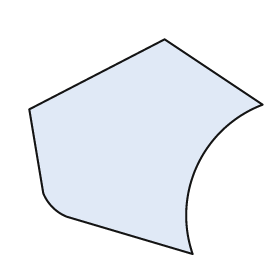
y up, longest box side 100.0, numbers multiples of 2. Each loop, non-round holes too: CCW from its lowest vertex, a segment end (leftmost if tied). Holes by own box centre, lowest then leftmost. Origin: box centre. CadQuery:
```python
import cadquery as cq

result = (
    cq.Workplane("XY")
    .moveTo(20.0, -46.0)
    .threePointArc((22.0, -8.0), (50.0, 18.0))
    .lineTo(8.0, 46.0)
    .lineTo(-50.0, 16.0)
    .lineTo(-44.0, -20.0)
    .threePointArc((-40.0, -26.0), (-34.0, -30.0))
    .close()
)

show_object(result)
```